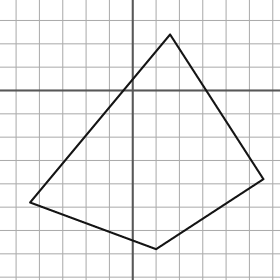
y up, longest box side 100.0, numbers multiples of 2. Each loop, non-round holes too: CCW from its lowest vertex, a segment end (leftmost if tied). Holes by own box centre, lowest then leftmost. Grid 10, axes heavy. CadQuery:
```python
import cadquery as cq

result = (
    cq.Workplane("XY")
    .moveTo(10.0, -68.0)
    .lineTo(56.0, -38.0)
    .lineTo(16.0, 24.0)
    .lineTo(-44.0, -48.0)
    .close()
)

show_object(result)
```